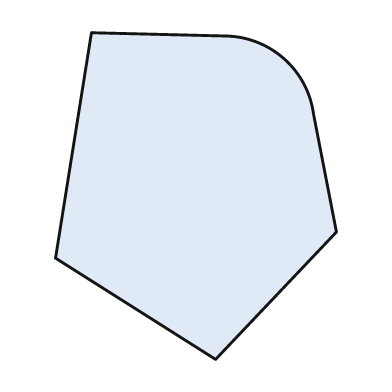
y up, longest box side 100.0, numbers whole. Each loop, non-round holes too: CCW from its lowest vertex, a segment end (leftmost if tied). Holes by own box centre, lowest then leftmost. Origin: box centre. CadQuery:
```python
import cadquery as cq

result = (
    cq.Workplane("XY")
    .moveTo(6.0, -50.0)
    .lineTo(43.0, -11.0)
    .lineTo(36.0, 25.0)
    .threePointArc((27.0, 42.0), (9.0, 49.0))
    .lineTo(-32.0, 50.0)
    .lineTo(-43.0, -19.0)
    .close()
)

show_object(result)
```